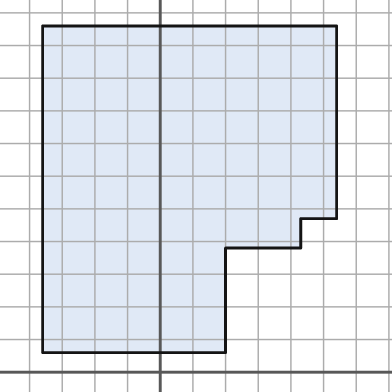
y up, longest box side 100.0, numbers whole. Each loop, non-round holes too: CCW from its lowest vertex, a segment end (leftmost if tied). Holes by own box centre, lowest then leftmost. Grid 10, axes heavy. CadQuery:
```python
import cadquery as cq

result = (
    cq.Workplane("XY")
    .moveTo(-36.0, 6.0)
    .lineTo(20.0, 6.0)
    .lineTo(20.0, 38.0)
    .lineTo(43.0, 38.0)
    .lineTo(43.0, 47.0)
    .lineTo(54.0, 47.0)
    .lineTo(54.0, 106.0)
    .lineTo(-36.0, 106.0)
    .close()
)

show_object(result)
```